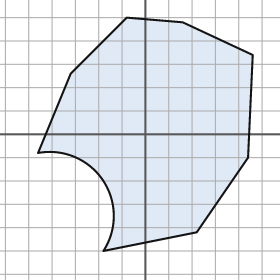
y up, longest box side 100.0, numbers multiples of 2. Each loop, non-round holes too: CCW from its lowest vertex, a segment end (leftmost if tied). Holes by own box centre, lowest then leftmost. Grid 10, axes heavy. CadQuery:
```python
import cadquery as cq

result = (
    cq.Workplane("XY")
    .moveTo(-18.0, -50.0)
    .lineTo(22.0, -42.0)
    .lineTo(44.0, -10.0)
    .lineTo(46.0, 34.0)
    .lineTo(16.0, 48.0)
    .lineTo(-8.0, 50.0)
    .lineTo(-32.0, 26.0)
    .lineTo(-46.0, -8.0)
    .threePointArc((-18.0, -20.0), (-18.0, -50.0))
    .close()
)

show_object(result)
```